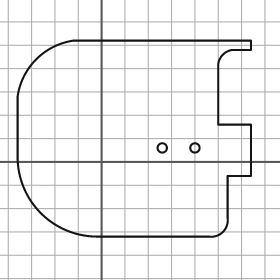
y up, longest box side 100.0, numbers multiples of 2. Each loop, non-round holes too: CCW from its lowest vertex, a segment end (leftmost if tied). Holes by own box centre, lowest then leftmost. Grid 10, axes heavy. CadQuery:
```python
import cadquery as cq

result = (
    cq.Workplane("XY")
    .moveTo(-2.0, -32.0)
    .lineTo(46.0, -32.0)
    .threePointArc((52.0, -30.0), (54.0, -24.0))
    .lineTo(54.0, -6.0)
    .lineTo(64.0, -6.0)
    .lineTo(64.0, 16.0)
    .lineTo(50.0, 16.0)
    .lineTo(50.0, 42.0)
    .threePointArc((52.0, 46.0), (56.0, 48.0))
    .lineTo(64.0, 48.0)
    .lineTo(64.0, 52.0)
    .lineTo(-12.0, 52.0)
    .threePointArc((-28.0, 44.0), (-36.0, 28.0))
    .lineTo(-36.0, 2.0)
    .threePointArc((-26.0, -22.0), (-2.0, -32.0))
    .close()
    .moveTo(26.0, 6.0)
    .circle(2.0)
    .moveTo(40.0, 6.0)
    .circle(2.0)
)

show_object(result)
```